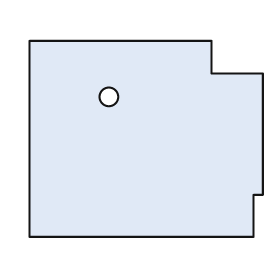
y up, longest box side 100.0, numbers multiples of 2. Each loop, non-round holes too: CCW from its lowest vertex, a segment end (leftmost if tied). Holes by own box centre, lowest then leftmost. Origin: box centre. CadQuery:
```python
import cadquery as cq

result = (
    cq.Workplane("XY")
    .moveTo(-50.0, -42.0)
    .lineTo(46.0, -42.0)
    .lineTo(46.0, -24.0)
    .lineTo(50.0, -24.0)
    .lineTo(50.0, 28.0)
    .lineTo(28.0, 28.0)
    .lineTo(28.0, 42.0)
    .lineTo(-50.0, 42.0)
    .close()
    .moveTo(-16.0, 18.0)
    .circle(4.0)
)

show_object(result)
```